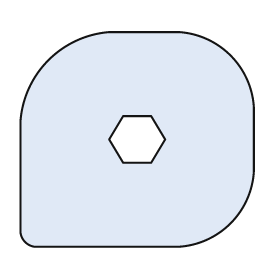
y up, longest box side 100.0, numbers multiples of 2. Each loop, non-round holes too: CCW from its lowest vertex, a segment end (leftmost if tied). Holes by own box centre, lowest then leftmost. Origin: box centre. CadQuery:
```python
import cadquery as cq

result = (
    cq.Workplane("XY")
    .moveTo(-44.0, -46.0)
    .lineTo(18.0, -46.0)
    .threePointArc((40.0, -36.0), (50.0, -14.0))
    .lineTo(50.0, 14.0)
    .threePointArc((40.0, 36.0), (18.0, 46.0))
    .lineTo(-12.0, 46.0)
    .threePointArc((-38.0, 34.0), (-50.0, 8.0))
    .lineTo(-50.0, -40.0)
    .threePointArc((-48.0, -44.0), (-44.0, -46.0))
    .close()
    .moveTo(-6.0, -10.0)
    .lineTo(6.0, -10.0)
    .lineTo(12.0, 0.0)
    .lineTo(6.0, 10.0)
    .lineTo(-6.0, 10.0)
    .lineTo(-12.0, 0.0)
    .close()
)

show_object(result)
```